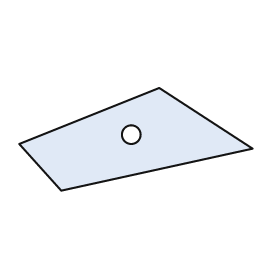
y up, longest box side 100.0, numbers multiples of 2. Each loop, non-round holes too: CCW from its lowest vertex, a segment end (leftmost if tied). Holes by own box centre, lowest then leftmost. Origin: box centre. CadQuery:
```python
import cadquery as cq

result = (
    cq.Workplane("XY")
    .moveTo(-32.0, -22.0)
    .lineTo(50.0, -4.0)
    .lineTo(10.0, 22.0)
    .lineTo(-50.0, -2.0)
    .close()
    .moveTo(-2.0, 2.0)
    .circle(4.0)
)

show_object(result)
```